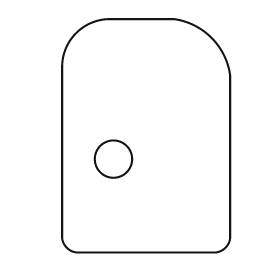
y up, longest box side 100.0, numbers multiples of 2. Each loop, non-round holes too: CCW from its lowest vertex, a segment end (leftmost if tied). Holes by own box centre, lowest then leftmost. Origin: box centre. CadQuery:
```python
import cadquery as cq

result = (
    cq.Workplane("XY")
    .moveTo(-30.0, -50.0)
    .lineTo(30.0, -50.0)
    .threePointArc((34.0, -48.0), (36.0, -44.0))
    .lineTo(36.0, 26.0)
    .threePointArc((28.0, 42.0), (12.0, 50.0))
    .lineTo(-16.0, 50.0)
    .threePointArc((-30.0, 44.0), (-36.0, 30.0))
    .lineTo(-36.0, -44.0)
    .threePointArc((-34.0, -48.0), (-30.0, -50.0))
    .close()
    .moveTo(-14.0, -10.0)
    .circle(8.0)
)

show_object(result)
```